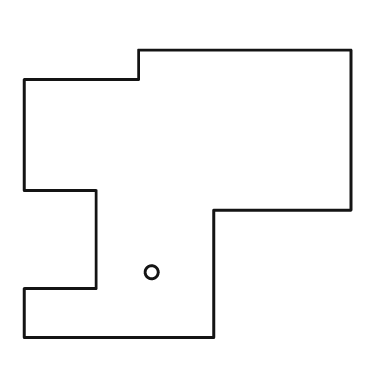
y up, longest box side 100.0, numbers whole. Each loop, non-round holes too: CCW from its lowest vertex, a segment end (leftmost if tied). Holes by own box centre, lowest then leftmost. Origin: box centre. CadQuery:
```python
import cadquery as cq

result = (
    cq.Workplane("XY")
    .moveTo(-50.0, -44.0)
    .lineTo(8.0, -44.0)
    .lineTo(8.0, -5.0)
    .lineTo(50.0, -5.0)
    .lineTo(50.0, 44.0)
    .lineTo(-15.0, 44.0)
    .lineTo(-15.0, 35.0)
    .lineTo(-50.0, 35.0)
    .lineTo(-50.0, 1.0)
    .lineTo(-28.0, 1.0)
    .lineTo(-28.0, -29.0)
    .lineTo(-50.0, -29.0)
    .close()
    .moveTo(-11.0, -24.0)
    .circle(2.0)
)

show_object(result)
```